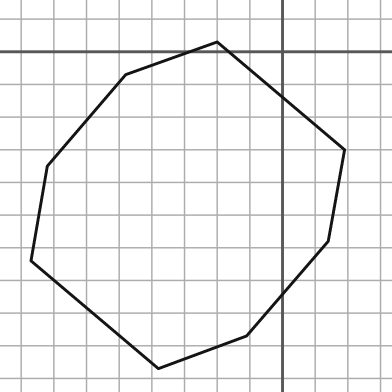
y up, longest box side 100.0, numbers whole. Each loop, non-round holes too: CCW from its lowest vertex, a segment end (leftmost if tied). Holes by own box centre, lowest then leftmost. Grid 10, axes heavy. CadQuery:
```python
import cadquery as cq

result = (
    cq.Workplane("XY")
    .moveTo(-38.0, -97.0)
    .lineTo(-11.0, -87.0)
    .lineTo(14.0, -58.0)
    .lineTo(19.0, -30.0)
    .lineTo(-20.0, 3.0)
    .lineTo(-48.0, -7.0)
    .lineTo(-72.0, -35.0)
    .lineTo(-77.0, -64.0)
    .close()
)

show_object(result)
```